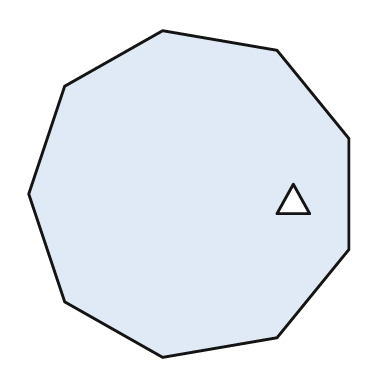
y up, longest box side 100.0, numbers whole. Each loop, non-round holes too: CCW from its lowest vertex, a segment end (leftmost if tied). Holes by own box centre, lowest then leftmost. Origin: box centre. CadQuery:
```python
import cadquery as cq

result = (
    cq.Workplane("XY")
    .moveTo(-8.0, -50.0)
    .lineTo(27.0, -44.0)
    .lineTo(49.0, -17.0)
    .lineTo(49.0, 17.0)
    .lineTo(27.0, 44.0)
    .lineTo(-8.0, 50.0)
    .lineTo(-38.0, 33.0)
    .lineTo(-49.0, 0.0)
    .lineTo(-38.0, -33.0)
    .close()
    .moveTo(27.0, -6.0)
    .lineTo(37.0, -6.0)
    .lineTo(32.0, 3.0)
    .close()
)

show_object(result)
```